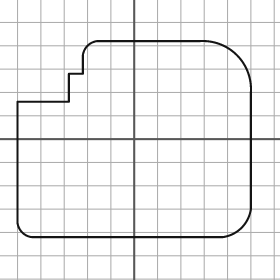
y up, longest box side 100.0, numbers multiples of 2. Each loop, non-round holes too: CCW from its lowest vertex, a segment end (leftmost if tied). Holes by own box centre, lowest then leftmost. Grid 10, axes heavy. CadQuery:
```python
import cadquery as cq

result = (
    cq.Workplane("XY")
    .moveTo(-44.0, -42.0)
    .lineTo(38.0, -42.0)
    .threePointArc((46.0, -38.0), (50.0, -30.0))
    .lineTo(50.0, 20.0)
    .threePointArc((44.0, 36.0), (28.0, 42.0))
    .lineTo(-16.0, 42.0)
    .threePointArc((-20.0, 40.0), (-22.0, 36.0))
    .lineTo(-22.0, 28.0)
    .lineTo(-28.0, 28.0)
    .lineTo(-28.0, 16.0)
    .lineTo(-50.0, 16.0)
    .lineTo(-50.0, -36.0)
    .threePointArc((-48.0, -40.0), (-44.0, -42.0))
    .close()
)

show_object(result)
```